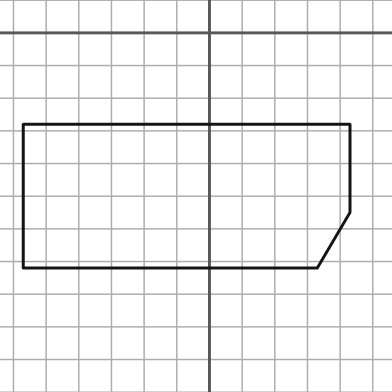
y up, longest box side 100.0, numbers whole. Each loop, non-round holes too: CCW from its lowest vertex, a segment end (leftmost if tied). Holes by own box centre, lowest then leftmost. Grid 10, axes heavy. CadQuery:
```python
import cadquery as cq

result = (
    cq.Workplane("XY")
    .moveTo(-57.0, -72.0)
    .lineTo(33.0, -72.0)
    .lineTo(43.0, -55.0)
    .lineTo(43.0, -28.0)
    .lineTo(-57.0, -28.0)
    .close()
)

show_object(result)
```